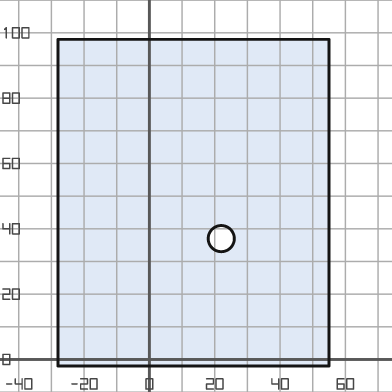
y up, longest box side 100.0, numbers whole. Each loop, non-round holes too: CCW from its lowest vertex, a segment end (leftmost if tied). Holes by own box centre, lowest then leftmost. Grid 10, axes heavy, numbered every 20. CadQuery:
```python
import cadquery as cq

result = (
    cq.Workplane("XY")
    .moveTo(-28.0, -2.0)
    .lineTo(55.0, -2.0)
    .lineTo(55.0, 98.0)
    .lineTo(-28.0, 98.0)
    .close()
    .moveTo(22.0, 37.0)
    .circle(4.0)
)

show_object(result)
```